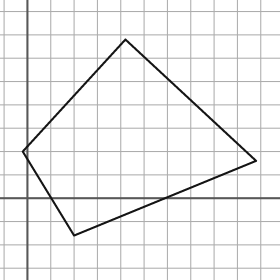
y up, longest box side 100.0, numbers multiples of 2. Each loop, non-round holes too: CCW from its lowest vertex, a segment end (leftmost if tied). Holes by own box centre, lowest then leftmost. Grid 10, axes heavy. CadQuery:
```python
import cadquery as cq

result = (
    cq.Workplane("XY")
    .moveTo(20.0, -16.0)
    .lineTo(98.0, 16.0)
    .lineTo(42.0, 68.0)
    .lineTo(-2.0, 20.0)
    .close()
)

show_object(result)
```